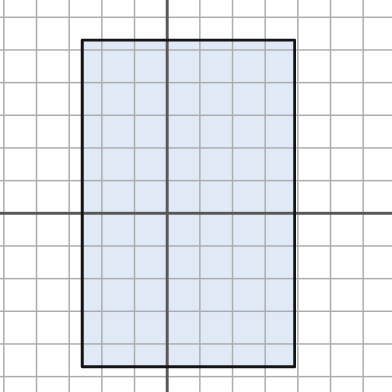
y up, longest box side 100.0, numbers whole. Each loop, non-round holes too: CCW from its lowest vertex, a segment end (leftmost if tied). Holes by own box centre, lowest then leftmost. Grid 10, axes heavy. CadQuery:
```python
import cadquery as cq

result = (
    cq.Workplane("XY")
    .moveTo(-26.0, -47.0)
    .lineTo(39.0, -47.0)
    .lineTo(39.0, 53.0)
    .lineTo(-26.0, 53.0)
    .close()
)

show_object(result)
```